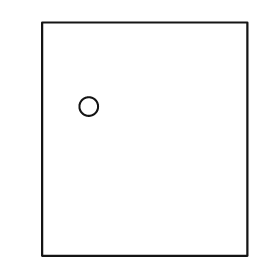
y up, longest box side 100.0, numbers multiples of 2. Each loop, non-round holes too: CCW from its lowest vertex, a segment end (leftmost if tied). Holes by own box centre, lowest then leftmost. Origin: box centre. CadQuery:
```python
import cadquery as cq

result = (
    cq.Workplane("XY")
    .moveTo(-44.0, -50.0)
    .lineTo(44.0, -50.0)
    .lineTo(44.0, 50.0)
    .lineTo(-44.0, 50.0)
    .close()
    .moveTo(-24.0, 14.0)
    .circle(4.0)
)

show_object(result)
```